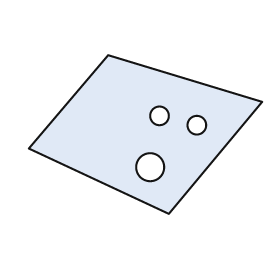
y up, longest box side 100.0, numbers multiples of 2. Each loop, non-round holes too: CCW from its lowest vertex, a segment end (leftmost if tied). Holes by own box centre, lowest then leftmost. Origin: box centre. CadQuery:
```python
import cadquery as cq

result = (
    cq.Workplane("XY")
    .moveTo(10.0, -34.0)
    .lineTo(50.0, 14.0)
    .lineTo(-16.0, 34.0)
    .lineTo(-50.0, -6.0)
    .close()
    .moveTo(2.0, -14.0)
    .circle(6.0)
    .moveTo(22.0, 4.0)
    .circle(4.0)
    .moveTo(6.0, 8.0)
    .circle(4.0)
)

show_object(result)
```